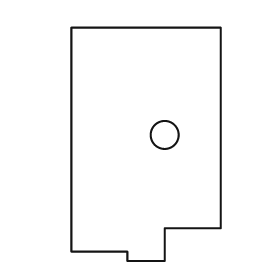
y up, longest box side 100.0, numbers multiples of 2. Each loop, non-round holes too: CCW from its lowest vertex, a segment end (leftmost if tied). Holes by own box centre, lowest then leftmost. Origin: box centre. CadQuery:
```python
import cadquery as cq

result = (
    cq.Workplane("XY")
    .moveTo(-8.0, -50.0)
    .lineTo(8.0, -50.0)
    .lineTo(8.0, -36.0)
    .lineTo(32.0, -36.0)
    .lineTo(32.0, 50.0)
    .lineTo(-32.0, 50.0)
    .lineTo(-32.0, -46.0)
    .lineTo(-8.0, -46.0)
    .close()
    .moveTo(8.0, 4.0)
    .circle(6.0)
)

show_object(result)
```